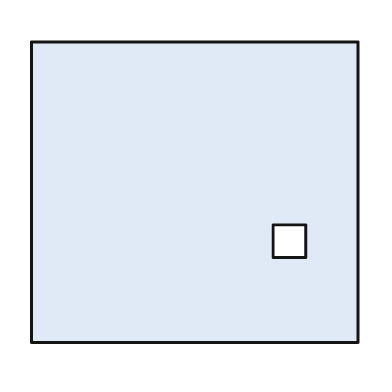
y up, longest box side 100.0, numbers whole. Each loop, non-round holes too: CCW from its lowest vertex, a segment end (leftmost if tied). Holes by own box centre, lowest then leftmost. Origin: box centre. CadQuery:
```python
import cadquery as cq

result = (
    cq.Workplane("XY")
    .moveTo(-50.0, -46.0)
    .lineTo(50.0, -46.0)
    .lineTo(50.0, 46.0)
    .lineTo(-50.0, 46.0)
    .close()
    .moveTo(24.0, -20.0)
    .lineTo(34.0, -20.0)
    .lineTo(34.0, -10.0)
    .lineTo(24.0, -10.0)
    .close()
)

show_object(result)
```